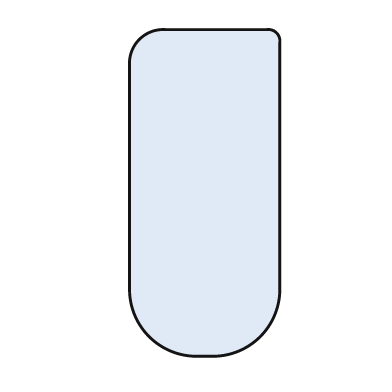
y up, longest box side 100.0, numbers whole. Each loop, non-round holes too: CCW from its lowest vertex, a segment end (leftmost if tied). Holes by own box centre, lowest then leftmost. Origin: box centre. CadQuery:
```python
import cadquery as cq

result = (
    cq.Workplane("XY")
    .moveTo(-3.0, -50.0)
    .lineTo(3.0, -50.0)
    .threePointArc((17.0, -44.0), (23.0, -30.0))
    .lineTo(23.0, 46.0)
    .threePointArc((22.0, 49.0), (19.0, 50.0))
    .lineTo(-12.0, 50.0)
    .threePointArc((-20.0, 47.0), (-23.0, 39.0))
    .lineTo(-23.0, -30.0)
    .threePointArc((-17.0, -44.0), (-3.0, -50.0))
    .close()
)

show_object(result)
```